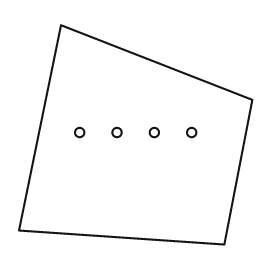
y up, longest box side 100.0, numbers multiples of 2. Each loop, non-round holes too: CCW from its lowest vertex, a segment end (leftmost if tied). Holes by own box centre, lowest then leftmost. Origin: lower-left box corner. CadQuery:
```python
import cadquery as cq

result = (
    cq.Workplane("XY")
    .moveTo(88.0, 0.0)
    .lineTo(100.0, 62.0)
    .lineTo(18.0, 94.0)
    .lineTo(0.0, 6.0)
    .close()
    .moveTo(26.0, 48.0)
    .circle(2.0)
    .moveTo(42.0, 48.0)
    .circle(2.0)
    .moveTo(58.0, 48.0)
    .circle(2.0)
    .moveTo(74.0, 48.0)
    .circle(2.0)
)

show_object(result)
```